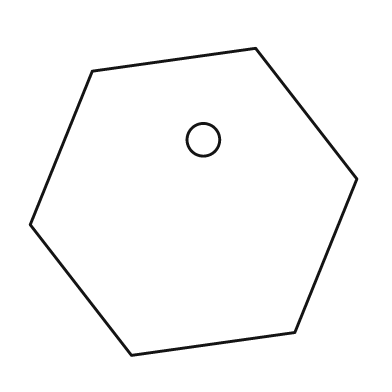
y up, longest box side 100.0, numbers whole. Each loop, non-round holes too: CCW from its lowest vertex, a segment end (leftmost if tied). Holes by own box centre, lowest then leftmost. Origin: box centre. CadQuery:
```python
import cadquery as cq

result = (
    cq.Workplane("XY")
    .moveTo(-19.0, -47.0)
    .lineTo(31.0, -40.0)
    .lineTo(50.0, 7.0)
    .lineTo(19.0, 47.0)
    .lineTo(-31.0, 40.0)
    .lineTo(-50.0, -7.0)
    .close()
    .moveTo(3.0, 19.0)
    .circle(5.0)
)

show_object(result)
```